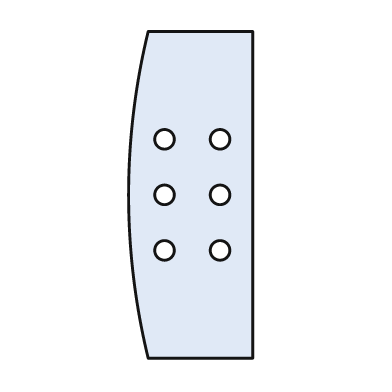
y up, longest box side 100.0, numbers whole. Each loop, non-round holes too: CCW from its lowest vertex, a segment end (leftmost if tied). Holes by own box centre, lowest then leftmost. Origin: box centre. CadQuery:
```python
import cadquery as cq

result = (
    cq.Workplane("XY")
    .moveTo(-13.0, -50.0)
    .lineTo(19.0, -50.0)
    .lineTo(19.0, 50.0)
    .lineTo(-13.0, 50.0)
    .threePointArc((-19.0, 0.0), (-13.0, -50.0))
    .close()
    .moveTo(-8.0, -17.0)
    .circle(3.0)
    .moveTo(9.0, -17.0)
    .circle(3.0)
    .moveTo(-8.0, 0.0)
    .circle(3.0)
    .moveTo(9.0, 0.0)
    .circle(3.0)
    .moveTo(-8.0, 17.0)
    .circle(3.0)
    .moveTo(9.0, 17.0)
    .circle(3.0)
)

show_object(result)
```